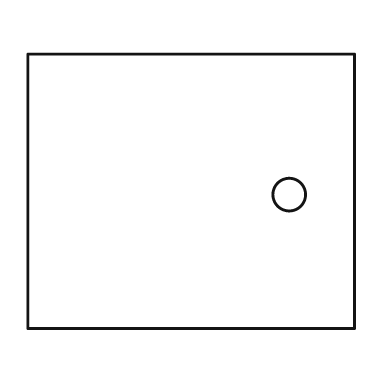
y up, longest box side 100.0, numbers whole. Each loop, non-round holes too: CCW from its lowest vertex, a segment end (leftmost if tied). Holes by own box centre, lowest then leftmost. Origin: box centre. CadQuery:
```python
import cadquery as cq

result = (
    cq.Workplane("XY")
    .moveTo(-50.0, -42.0)
    .lineTo(50.0, -42.0)
    .lineTo(50.0, 42.0)
    .lineTo(-50.0, 42.0)
    .close()
    .moveTo(30.0, -1.0)
    .circle(5.0)
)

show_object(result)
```